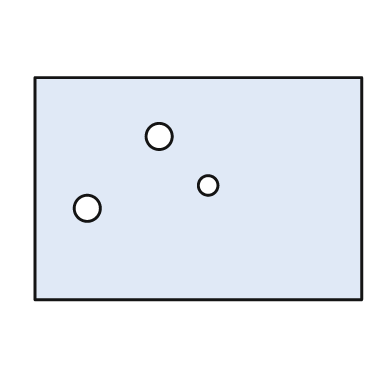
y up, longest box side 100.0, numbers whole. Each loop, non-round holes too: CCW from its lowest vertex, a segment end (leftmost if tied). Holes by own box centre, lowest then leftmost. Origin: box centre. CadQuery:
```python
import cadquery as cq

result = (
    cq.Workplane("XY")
    .moveTo(-50.0, -34.0)
    .lineTo(50.0, -34.0)
    .lineTo(50.0, 34.0)
    .lineTo(-50.0, 34.0)
    .close()
    .moveTo(-34.0, -6.0)
    .circle(4.0)
    .moveTo(3.0, 1.0)
    .circle(3.0)
    .moveTo(-12.0, 16.0)
    .circle(4.0)
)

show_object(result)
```